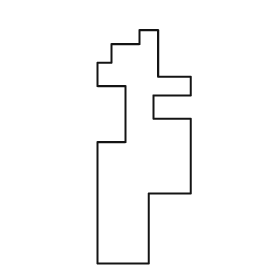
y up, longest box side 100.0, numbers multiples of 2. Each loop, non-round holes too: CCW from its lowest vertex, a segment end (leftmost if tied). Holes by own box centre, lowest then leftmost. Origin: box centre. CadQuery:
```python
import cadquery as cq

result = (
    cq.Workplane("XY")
    .moveTo(-20.0, -50.0)
    .lineTo(2.0, -50.0)
    .lineTo(2.0, -20.0)
    .lineTo(20.0, -20.0)
    .lineTo(20.0, 12.0)
    .lineTo(4.0, 12.0)
    .lineTo(4.0, 22.0)
    .lineTo(20.0, 22.0)
    .lineTo(20.0, 30.0)
    .lineTo(6.0, 30.0)
    .lineTo(6.0, 50.0)
    .lineTo(-2.0, 50.0)
    .lineTo(-2.0, 44.0)
    .lineTo(-14.0, 44.0)
    .lineTo(-14.0, 36.0)
    .lineTo(-20.0, 36.0)
    .lineTo(-20.0, 26.0)
    .lineTo(-8.0, 26.0)
    .lineTo(-8.0, 2.0)
    .lineTo(-20.0, 2.0)
    .close()
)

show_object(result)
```